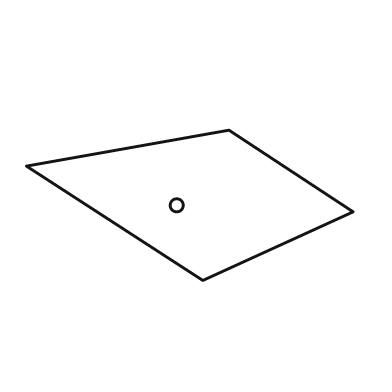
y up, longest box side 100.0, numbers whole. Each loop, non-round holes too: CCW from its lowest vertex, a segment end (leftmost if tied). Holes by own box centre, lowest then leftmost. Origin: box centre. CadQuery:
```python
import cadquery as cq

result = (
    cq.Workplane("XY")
    .moveTo(4.0, -23.0)
    .lineTo(50.0, -2.0)
    .lineTo(12.0, 23.0)
    .lineTo(-50.0, 12.0)
    .close()
    .moveTo(-4.0, 0.0)
    .circle(2.0)
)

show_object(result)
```